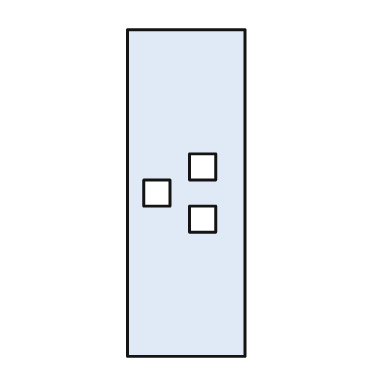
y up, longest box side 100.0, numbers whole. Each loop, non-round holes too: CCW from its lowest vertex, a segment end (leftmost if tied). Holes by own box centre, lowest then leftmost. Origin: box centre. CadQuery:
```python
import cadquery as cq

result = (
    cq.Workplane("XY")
    .moveTo(-18.0, -50.0)
    .lineTo(18.0, -50.0)
    .lineTo(18.0, 50.0)
    .lineTo(-18.0, 50.0)
    .close()
    .moveTo(1.0, -12.0)
    .lineTo(9.0, -12.0)
    .lineTo(9.0, -4.0)
    .lineTo(1.0, -4.0)
    .close()
    .moveTo(-13.0, -4.0)
    .lineTo(-5.0, -4.0)
    .lineTo(-5.0, 4.0)
    .lineTo(-13.0, 4.0)
    .close()
    .moveTo(1.0, 4.0)
    .lineTo(9.0, 4.0)
    .lineTo(9.0, 12.0)
    .lineTo(1.0, 12.0)
    .close()
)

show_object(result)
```